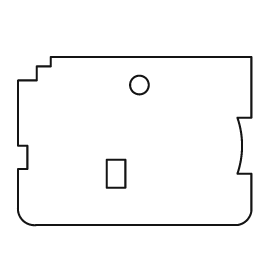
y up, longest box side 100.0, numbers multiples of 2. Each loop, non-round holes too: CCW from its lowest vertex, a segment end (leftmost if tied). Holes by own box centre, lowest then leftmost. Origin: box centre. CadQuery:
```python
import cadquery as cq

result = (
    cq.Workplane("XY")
    .moveTo(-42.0, -36.0)
    .lineTo(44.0, -36.0)
    .threePointArc((48.0, -34.0), (50.0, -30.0))
    .lineTo(50.0, -14.0)
    .lineTo(44.0, -14.0)
    .threePointArc((46.0, -2.0), (44.0, 10.0))
    .lineTo(50.0, 10.0)
    .lineTo(50.0, 36.0)
    .lineTo(-36.0, 36.0)
    .lineTo(-36.0, 32.0)
    .lineTo(-42.0, 32.0)
    .lineTo(-42.0, 26.0)
    .lineTo(-50.0, 26.0)
    .lineTo(-50.0, -2.0)
    .lineTo(-46.0, -2.0)
    .lineTo(-46.0, -12.0)
    .lineTo(-50.0, -12.0)
    .lineTo(-50.0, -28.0)
    .threePointArc((-48.0, -34.0), (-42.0, -36.0))
    .close()
    .moveTo(-12.0, -20.0)
    .lineTo(-4.0, -20.0)
    .lineTo(-4.0, -8.0)
    .lineTo(-12.0, -8.0)
    .close()
    .moveTo(2.0, 24.0)
    .circle(4.0)
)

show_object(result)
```